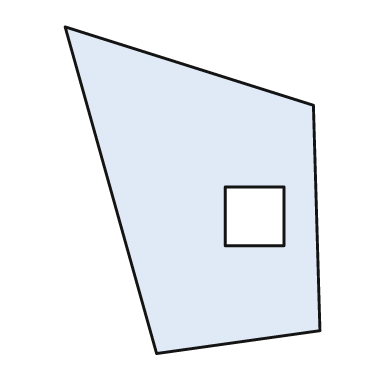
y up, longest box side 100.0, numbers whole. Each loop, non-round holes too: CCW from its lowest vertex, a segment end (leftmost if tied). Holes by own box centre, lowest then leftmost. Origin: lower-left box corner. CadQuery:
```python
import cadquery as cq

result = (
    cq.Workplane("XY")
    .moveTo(28.0, 0.0)
    .lineTo(78.0, 7.0)
    .lineTo(76.0, 76.0)
    .lineTo(0.0, 100.0)
    .close()
    .moveTo(49.0, 33.0)
    .lineTo(67.0, 33.0)
    .lineTo(67.0, 51.0)
    .lineTo(49.0, 51.0)
    .close()
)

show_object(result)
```